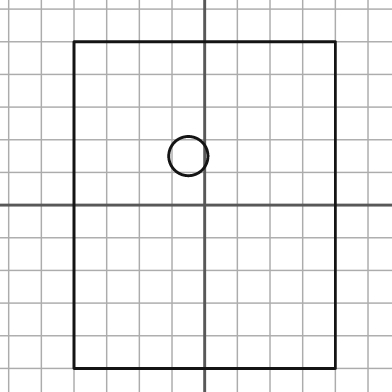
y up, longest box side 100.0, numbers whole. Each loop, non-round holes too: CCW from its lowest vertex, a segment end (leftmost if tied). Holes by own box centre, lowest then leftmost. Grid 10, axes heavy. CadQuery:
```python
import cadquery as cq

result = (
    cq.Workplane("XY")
    .moveTo(-40.0, -50.0)
    .lineTo(40.0, -50.0)
    .lineTo(40.0, 50.0)
    .lineTo(-40.0, 50.0)
    .close()
    .moveTo(-5.0, 15.0)
    .circle(6.0)
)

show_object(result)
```